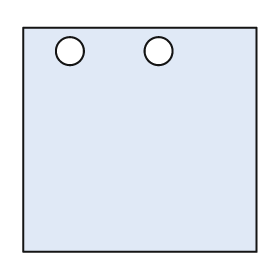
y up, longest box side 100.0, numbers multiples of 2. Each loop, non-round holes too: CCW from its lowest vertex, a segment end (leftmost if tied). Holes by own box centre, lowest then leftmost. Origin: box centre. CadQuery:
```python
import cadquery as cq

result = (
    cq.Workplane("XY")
    .moveTo(-50.0, -48.0)
    .lineTo(50.0, -48.0)
    .lineTo(50.0, 48.0)
    .lineTo(-50.0, 48.0)
    .close()
    .moveTo(-30.0, 38.0)
    .circle(6.0)
    .moveTo(8.0, 38.0)
    .circle(6.0)
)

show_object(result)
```